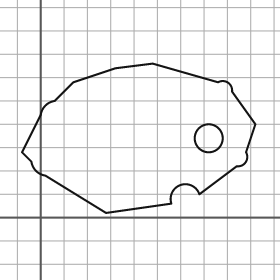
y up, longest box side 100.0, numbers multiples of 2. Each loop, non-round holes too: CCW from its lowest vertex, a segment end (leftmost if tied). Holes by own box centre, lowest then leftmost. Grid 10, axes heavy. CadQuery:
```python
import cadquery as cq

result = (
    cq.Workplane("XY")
    .moveTo(28.0, 2.0)
    .lineTo(56.0, 6.0)
    .threePointArc((60.0, 14.0), (68.0, 10.0))
    .lineTo(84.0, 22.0)
    .threePointArc((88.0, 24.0), (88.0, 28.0))
    .lineTo(92.0, 40.0)
    .lineTo(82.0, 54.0)
    .threePointArc((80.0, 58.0), (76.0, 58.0))
    .lineTo(48.0, 66.0)
    .lineTo(32.0, 64.0)
    .lineTo(14.0, 58.0)
    .lineTo(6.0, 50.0)
    .threePointArc((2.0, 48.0), (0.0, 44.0))
    .lineTo(-8.0, 28.0)
    .lineTo(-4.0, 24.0)
    .threePointArc((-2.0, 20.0), (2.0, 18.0))
    .close()
    .moveTo(72.0, 34.0)
    .circle(6.0)
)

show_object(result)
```